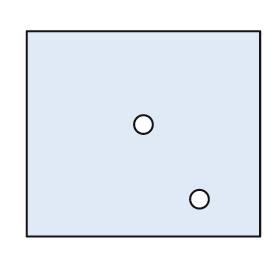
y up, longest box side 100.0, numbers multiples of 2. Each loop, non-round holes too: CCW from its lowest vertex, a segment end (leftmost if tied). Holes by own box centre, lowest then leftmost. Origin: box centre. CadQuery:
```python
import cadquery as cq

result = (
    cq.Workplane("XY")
    .moveTo(-50.0, -44.0)
    .lineTo(50.0, -44.0)
    .lineTo(50.0, 44.0)
    .lineTo(-50.0, 44.0)
    .close()
    .moveTo(24.0, -28.0)
    .circle(4.0)
    .moveTo(0.0, 4.0)
    .circle(4.0)
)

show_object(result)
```